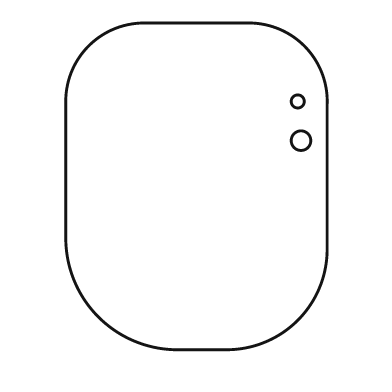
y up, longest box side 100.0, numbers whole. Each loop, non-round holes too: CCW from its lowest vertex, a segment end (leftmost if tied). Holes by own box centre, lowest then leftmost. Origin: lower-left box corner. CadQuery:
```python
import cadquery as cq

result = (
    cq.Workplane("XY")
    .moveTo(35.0, 0.0)
    .lineTo(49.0, 0.0)
    .threePointArc((71.0, 9.0), (80.0, 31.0))
    .lineTo(80.0, 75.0)
    .threePointArc((73.0, 93.0), (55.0, 100.0))
    .lineTo(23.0, 100.0)
    .threePointArc((7.0, 93.0), (0.0, 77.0))
    .lineTo(0.0, 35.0)
    .threePointArc((10.0, 10.0), (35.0, 0.0))
    .close()
    .moveTo(72.0, 64.0)
    .circle(3.0)
    .moveTo(71.0, 76.0)
    .circle(2.0)
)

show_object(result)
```